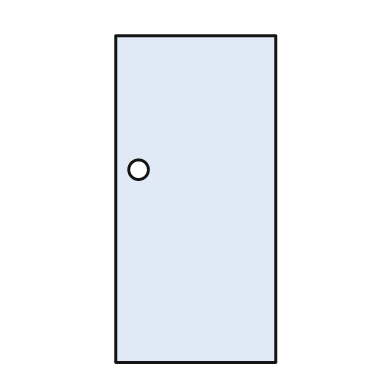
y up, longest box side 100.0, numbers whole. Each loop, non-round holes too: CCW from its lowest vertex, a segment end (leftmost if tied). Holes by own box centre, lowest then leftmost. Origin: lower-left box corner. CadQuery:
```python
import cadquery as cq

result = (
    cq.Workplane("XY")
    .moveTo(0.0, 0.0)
    .lineTo(49.0, 0.0)
    .lineTo(49.0, 100.0)
    .lineTo(0.0, 100.0)
    .close()
    .moveTo(7.0, 59.0)
    .circle(3.0)
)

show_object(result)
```